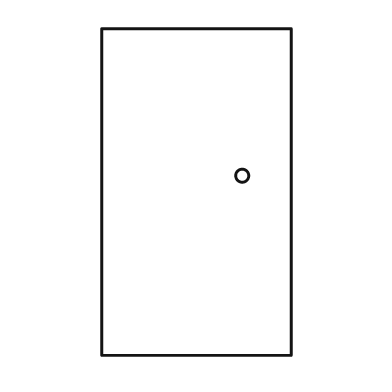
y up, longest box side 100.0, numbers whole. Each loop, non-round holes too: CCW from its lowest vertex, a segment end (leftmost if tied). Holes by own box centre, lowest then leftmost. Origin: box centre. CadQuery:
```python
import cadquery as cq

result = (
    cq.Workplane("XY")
    .moveTo(-29.0, -50.0)
    .lineTo(29.0, -50.0)
    .lineTo(29.0, 50.0)
    .lineTo(-29.0, 50.0)
    .close()
    .moveTo(14.0, 5.0)
    .circle(2.0)
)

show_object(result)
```